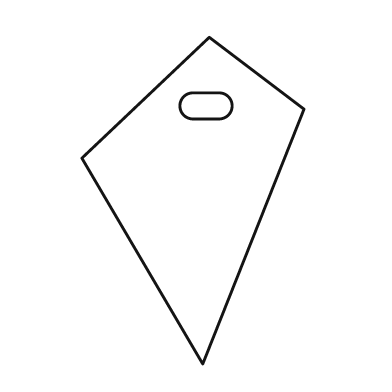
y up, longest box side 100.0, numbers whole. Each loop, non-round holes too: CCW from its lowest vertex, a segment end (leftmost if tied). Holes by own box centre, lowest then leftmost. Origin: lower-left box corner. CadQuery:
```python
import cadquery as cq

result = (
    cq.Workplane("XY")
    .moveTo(37.0, 0.0)
    .lineTo(68.0, 78.0)
    .lineTo(39.0, 100.0)
    .lineTo(0.0, 63.0)
    .close()
    .moveTo(34.0, 75.0)
    .lineTo(42.0, 75.0)
    .threePointArc((46.0, 79.0), (42.0, 83.0))
    .lineTo(34.0, 83.0)
    .threePointArc((30.0, 79.0), (34.0, 75.0))
    .close()
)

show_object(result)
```